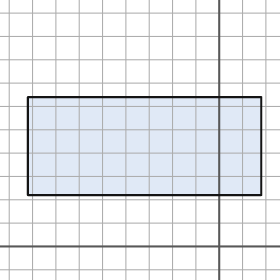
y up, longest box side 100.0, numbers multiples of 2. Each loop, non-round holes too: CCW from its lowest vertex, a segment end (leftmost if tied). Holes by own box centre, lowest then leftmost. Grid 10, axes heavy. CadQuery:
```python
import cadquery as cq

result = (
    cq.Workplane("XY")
    .moveTo(-82.0, 22.0)
    .lineTo(18.0, 22.0)
    .lineTo(18.0, 64.0)
    .lineTo(-82.0, 64.0)
    .close()
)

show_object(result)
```